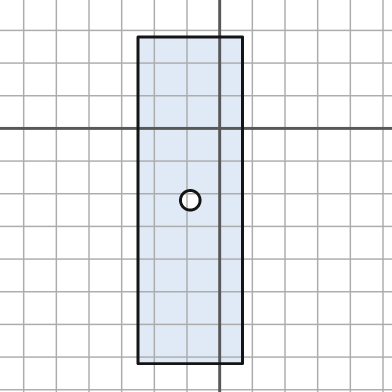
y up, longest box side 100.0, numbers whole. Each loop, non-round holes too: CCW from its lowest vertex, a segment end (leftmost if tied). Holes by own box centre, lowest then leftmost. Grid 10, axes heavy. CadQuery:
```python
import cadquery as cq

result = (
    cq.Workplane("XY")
    .moveTo(-25.0, -72.0)
    .lineTo(7.0, -72.0)
    .lineTo(7.0, 28.0)
    .lineTo(-25.0, 28.0)
    .close()
    .moveTo(-9.0, -22.0)
    .circle(3.0)
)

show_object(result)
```